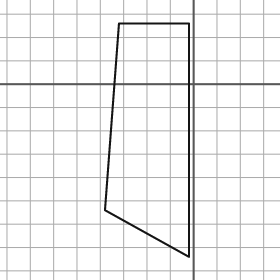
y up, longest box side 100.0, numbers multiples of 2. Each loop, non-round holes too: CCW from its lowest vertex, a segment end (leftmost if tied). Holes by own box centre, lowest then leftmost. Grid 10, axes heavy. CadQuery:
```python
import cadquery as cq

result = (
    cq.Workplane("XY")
    .moveTo(-2.0, -74.0)
    .lineTo(-2.0, 26.0)
    .lineTo(-32.0, 26.0)
    .lineTo(-38.0, -54.0)
    .close()
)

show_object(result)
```